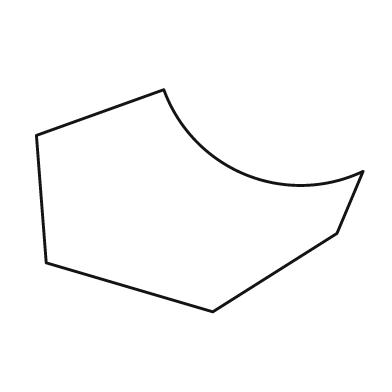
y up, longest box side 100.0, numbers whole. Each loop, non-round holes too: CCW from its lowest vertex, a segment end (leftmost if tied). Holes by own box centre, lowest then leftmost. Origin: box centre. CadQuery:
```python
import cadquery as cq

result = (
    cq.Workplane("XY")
    .moveTo(4.0, -34.0)
    .lineTo(42.0, -10.0)
    .lineTo(50.0, 9.0)
    .threePointArc((14.0, 8.0), (-11.0, 34.0))
    .lineTo(-50.0, 20.0)
    .lineTo(-47.0, -19.0)
    .close()
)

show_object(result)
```